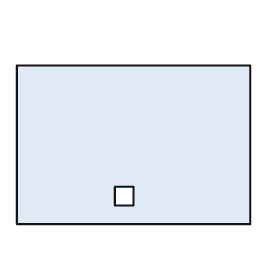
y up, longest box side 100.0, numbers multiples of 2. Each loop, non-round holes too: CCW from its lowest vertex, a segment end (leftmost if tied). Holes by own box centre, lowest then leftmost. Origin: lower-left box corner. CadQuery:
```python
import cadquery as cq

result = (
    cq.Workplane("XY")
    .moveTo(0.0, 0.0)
    .lineTo(100.0, 0.0)
    .lineTo(100.0, 68.0)
    .lineTo(0.0, 68.0)
    .close()
    .moveTo(42.0, 8.0)
    .lineTo(50.0, 8.0)
    .lineTo(50.0, 16.0)
    .lineTo(42.0, 16.0)
    .close()
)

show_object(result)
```